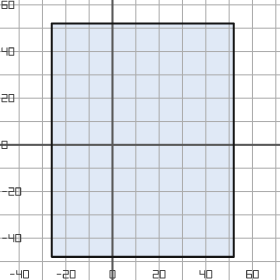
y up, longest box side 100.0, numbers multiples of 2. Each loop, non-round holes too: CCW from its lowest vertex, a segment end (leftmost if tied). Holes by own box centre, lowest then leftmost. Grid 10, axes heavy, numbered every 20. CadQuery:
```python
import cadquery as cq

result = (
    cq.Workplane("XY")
    .moveTo(-26.0, -48.0)
    .lineTo(52.0, -48.0)
    .lineTo(52.0, 52.0)
    .lineTo(-26.0, 52.0)
    .close()
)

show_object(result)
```